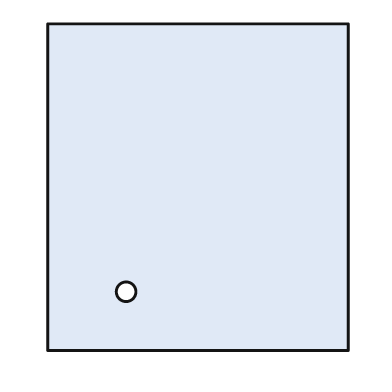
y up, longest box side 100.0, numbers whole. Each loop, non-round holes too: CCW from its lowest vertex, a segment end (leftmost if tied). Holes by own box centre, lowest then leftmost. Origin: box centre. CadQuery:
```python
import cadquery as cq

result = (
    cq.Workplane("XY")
    .moveTo(-46.0, -50.0)
    .lineTo(46.0, -50.0)
    .lineTo(46.0, 50.0)
    .lineTo(-46.0, 50.0)
    .close()
    .moveTo(-22.0, -32.0)
    .circle(3.0)
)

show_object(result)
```